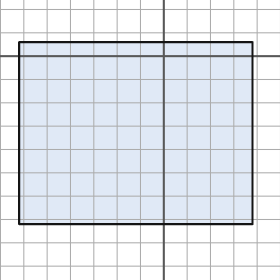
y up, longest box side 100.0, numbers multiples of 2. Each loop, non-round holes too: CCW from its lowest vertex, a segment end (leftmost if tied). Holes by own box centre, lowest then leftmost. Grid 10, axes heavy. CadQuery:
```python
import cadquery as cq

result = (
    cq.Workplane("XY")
    .moveTo(-62.0, -72.0)
    .lineTo(38.0, -72.0)
    .lineTo(38.0, 6.0)
    .lineTo(-62.0, 6.0)
    .close()
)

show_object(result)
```